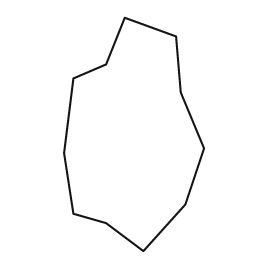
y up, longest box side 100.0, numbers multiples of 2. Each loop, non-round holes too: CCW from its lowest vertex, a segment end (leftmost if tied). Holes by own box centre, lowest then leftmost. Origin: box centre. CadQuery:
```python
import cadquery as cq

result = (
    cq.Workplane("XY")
    .moveTo(4.0, -50.0)
    .lineTo(22.0, -30.0)
    .lineTo(30.0, -6.0)
    .lineTo(20.0, 18.0)
    .lineTo(18.0, 42.0)
    .lineTo(-4.0, 50.0)
    .lineTo(-12.0, 30.0)
    .lineTo(-26.0, 24.0)
    .lineTo(-30.0, -8.0)
    .lineTo(-26.0, -34.0)
    .lineTo(-12.0, -38.0)
    .close()
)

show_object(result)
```